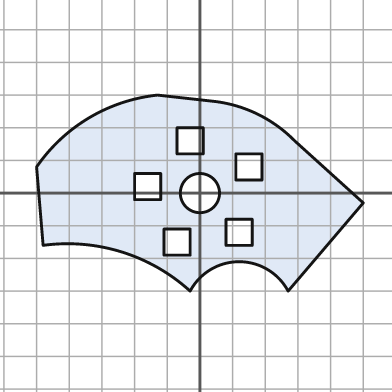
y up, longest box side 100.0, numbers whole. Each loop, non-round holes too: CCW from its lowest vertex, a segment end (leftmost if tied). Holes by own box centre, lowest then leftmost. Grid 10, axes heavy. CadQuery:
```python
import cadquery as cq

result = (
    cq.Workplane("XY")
    .moveTo(-3.0, -30.0)
    .threePointArc((12.0, -21.0), (27.0, -30.0))
    .lineTo(50.0, -3.0)
    .lineTo(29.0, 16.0)
    .threePointArc((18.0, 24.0), (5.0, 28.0))
    .lineTo(-13.0, 30.0)
    .threePointArc((-34.0, 23.0), (-50.0, 8.0))
    .lineTo(-48.0, -16.0)
    .threePointArc((-24.0, -18.0), (-3.0, -30.0))
    .close()
    .moveTo(-11.0, -19.0)
    .lineTo(-3.0, -19.0)
    .lineTo(-3.0, -11.0)
    .lineTo(-11.0, -11.0)
    .close()
    .moveTo(8.0, -16.0)
    .lineTo(16.0, -16.0)
    .lineTo(16.0, -8.0)
    .lineTo(8.0, -8.0)
    .close()
    .moveTo(0.0, 0.0)
    .circle(6.0)
    .moveTo(-20.0, -2.0)
    .lineTo(-12.0, -2.0)
    .lineTo(-12.0, 6.0)
    .lineTo(-20.0, 6.0)
    .close()
    .moveTo(11.0, 4.0)
    .lineTo(19.0, 4.0)
    .lineTo(19.0, 12.0)
    .lineTo(11.0, 12.0)
    .close()
    .moveTo(-7.0, 12.0)
    .lineTo(1.0, 12.0)
    .lineTo(1.0, 20.0)
    .lineTo(-7.0, 20.0)
    .close()
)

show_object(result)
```